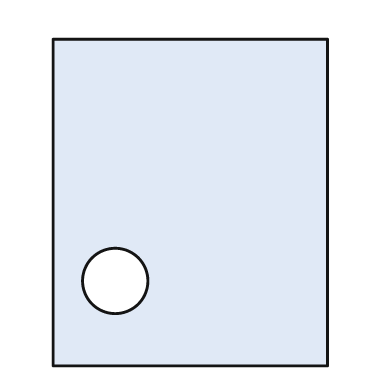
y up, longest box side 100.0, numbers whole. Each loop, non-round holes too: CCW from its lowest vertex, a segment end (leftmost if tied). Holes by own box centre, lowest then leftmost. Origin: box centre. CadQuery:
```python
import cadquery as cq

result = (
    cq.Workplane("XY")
    .moveTo(-42.0, -50.0)
    .lineTo(42.0, -50.0)
    .lineTo(42.0, 50.0)
    .lineTo(-42.0, 50.0)
    .close()
    .moveTo(-23.0, -24.0)
    .circle(10.0)
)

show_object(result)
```